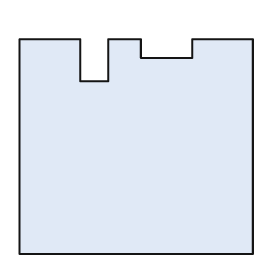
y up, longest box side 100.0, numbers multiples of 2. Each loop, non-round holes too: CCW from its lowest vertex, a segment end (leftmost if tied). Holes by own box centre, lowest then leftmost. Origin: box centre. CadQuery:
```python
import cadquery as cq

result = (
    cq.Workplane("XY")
    .moveTo(-50.0, -46.0)
    .lineTo(50.0, -46.0)
    .lineTo(50.0, 46.0)
    .lineTo(24.0, 46.0)
    .lineTo(24.0, 38.0)
    .lineTo(2.0, 38.0)
    .lineTo(2.0, 46.0)
    .lineTo(-12.0, 46.0)
    .lineTo(-12.0, 28.0)
    .lineTo(-24.0, 28.0)
    .lineTo(-24.0, 46.0)
    .lineTo(-50.0, 46.0)
    .close()
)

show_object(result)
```